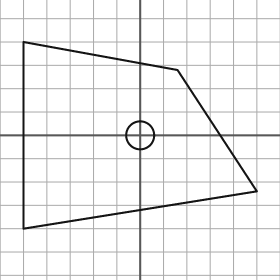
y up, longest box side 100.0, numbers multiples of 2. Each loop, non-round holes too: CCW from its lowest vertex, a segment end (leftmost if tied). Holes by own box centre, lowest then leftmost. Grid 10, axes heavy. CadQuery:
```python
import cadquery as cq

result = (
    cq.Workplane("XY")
    .moveTo(-50.0, -40.0)
    .lineTo(50.0, -24.0)
    .lineTo(16.0, 28.0)
    .lineTo(-50.0, 40.0)
    .close()
    .moveTo(0.0, 0.0)
    .circle(6.0)
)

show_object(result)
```